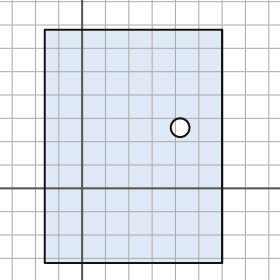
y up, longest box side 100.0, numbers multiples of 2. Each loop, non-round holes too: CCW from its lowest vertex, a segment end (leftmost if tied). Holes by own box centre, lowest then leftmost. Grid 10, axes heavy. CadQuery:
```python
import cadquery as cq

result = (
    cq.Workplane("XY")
    .moveTo(-16.0, -32.0)
    .lineTo(60.0, -32.0)
    .lineTo(60.0, 68.0)
    .lineTo(-16.0, 68.0)
    .close()
    .moveTo(42.0, 26.0)
    .circle(4.0)
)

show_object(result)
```